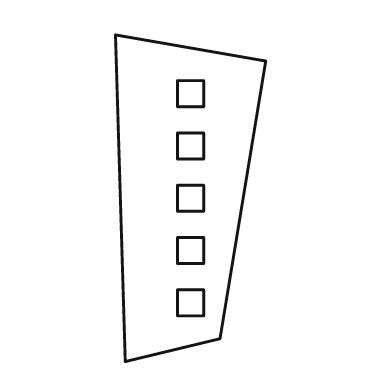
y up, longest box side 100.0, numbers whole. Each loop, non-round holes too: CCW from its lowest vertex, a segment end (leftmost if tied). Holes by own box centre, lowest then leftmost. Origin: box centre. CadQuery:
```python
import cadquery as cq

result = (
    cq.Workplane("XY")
    .moveTo(-20.0, -50.0)
    .lineTo(9.0, -43.0)
    .lineTo(23.0, 42.0)
    .lineTo(-23.0, 50.0)
    .close()
    .moveTo(-4.0, -36.0)
    .lineTo(4.0, -36.0)
    .lineTo(4.0, -28.0)
    .lineTo(-4.0, -28.0)
    .close()
    .moveTo(-4.0, -20.0)
    .lineTo(4.0, -20.0)
    .lineTo(4.0, -12.0)
    .lineTo(-4.0, -12.0)
    .close()
    .moveTo(-4.0, -4.0)
    .lineTo(4.0, -4.0)
    .lineTo(4.0, 4.0)
    .lineTo(-4.0, 4.0)
    .close()
    .moveTo(-4.0, 12.0)
    .lineTo(4.0, 12.0)
    .lineTo(4.0, 20.0)
    .lineTo(-4.0, 20.0)
    .close()
    .moveTo(-4.0, 28.0)
    .lineTo(4.0, 28.0)
    .lineTo(4.0, 36.0)
    .lineTo(-4.0, 36.0)
    .close()
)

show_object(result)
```